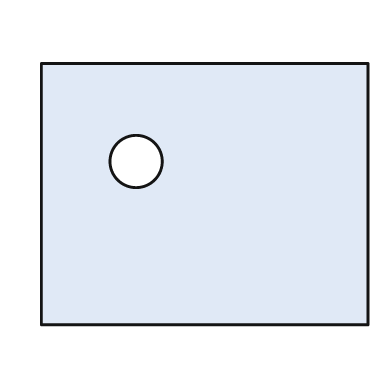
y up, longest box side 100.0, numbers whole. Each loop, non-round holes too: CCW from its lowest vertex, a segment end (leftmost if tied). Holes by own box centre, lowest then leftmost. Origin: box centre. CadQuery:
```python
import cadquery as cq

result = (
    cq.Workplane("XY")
    .moveTo(-50.0, -40.0)
    .lineTo(50.0, -40.0)
    .lineTo(50.0, 40.0)
    .lineTo(-50.0, 40.0)
    .close()
    .moveTo(-21.0, 10.0)
    .circle(8.0)
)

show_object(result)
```